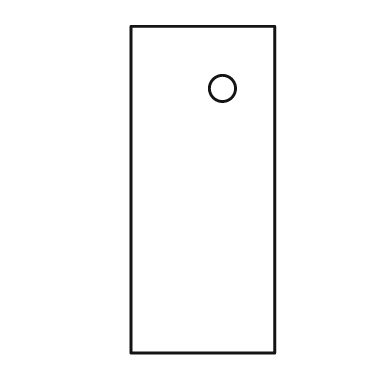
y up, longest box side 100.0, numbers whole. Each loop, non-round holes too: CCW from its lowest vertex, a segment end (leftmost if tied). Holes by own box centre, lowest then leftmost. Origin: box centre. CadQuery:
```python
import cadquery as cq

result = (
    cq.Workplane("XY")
    .moveTo(-22.0, -50.0)
    .lineTo(22.0, -50.0)
    .lineTo(22.0, 50.0)
    .lineTo(-22.0, 50.0)
    .close()
    .moveTo(6.0, 31.0)
    .circle(4.0)
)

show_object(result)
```